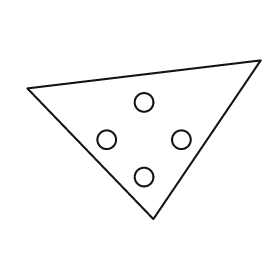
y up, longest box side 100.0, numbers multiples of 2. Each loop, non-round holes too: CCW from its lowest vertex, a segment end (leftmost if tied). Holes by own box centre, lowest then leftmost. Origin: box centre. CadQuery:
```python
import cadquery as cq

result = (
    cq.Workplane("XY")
    .moveTo(4.0, -34.0)
    .lineTo(50.0, 34.0)
    .lineTo(-50.0, 22.0)
    .close()
    .moveTo(0.0, -16.0)
    .circle(4.0)
    .moveTo(-16.0, 0.0)
    .circle(4.0)
    .moveTo(16.0, 0.0)
    .circle(4.0)
    .moveTo(0.0, 16.0)
    .circle(4.0)
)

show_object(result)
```